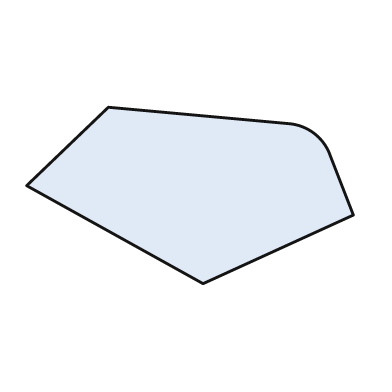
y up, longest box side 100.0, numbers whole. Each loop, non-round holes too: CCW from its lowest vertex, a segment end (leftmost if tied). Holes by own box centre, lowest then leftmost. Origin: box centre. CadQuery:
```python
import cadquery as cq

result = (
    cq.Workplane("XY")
    .moveTo(4.0, -27.0)
    .lineTo(50.0, -6.0)
    .lineTo(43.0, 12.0)
    .threePointArc((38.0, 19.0), (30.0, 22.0))
    .lineTo(-25.0, 27.0)
    .lineTo(-50.0, 3.0)
    .close()
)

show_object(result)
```